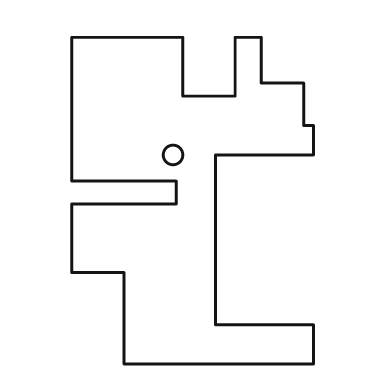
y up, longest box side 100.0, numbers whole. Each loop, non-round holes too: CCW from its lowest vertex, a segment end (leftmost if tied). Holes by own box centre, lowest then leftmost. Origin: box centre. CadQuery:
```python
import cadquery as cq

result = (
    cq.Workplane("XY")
    .moveTo(-21.0, -50.0)
    .lineTo(37.0, -50.0)
    .lineTo(37.0, -38.0)
    .lineTo(7.0, -38.0)
    .lineTo(7.0, 14.0)
    .lineTo(37.0, 14.0)
    .lineTo(37.0, 23.0)
    .lineTo(34.0, 23.0)
    .lineTo(34.0, 36.0)
    .lineTo(21.0, 36.0)
    .lineTo(21.0, 50.0)
    .lineTo(13.0, 50.0)
    .lineTo(13.0, 32.0)
    .lineTo(-3.0, 32.0)
    .lineTo(-3.0, 50.0)
    .lineTo(-37.0, 50.0)
    .lineTo(-37.0, 6.0)
    .lineTo(-5.0, 6.0)
    .lineTo(-5.0, -1.0)
    .lineTo(-37.0, -1.0)
    .lineTo(-37.0, -22.0)
    .lineTo(-21.0, -22.0)
    .close()
    .moveTo(-6.0, 14.0)
    .circle(3.0)
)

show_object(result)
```